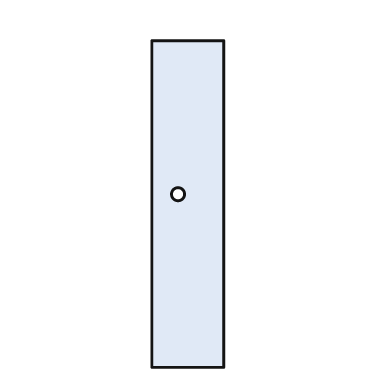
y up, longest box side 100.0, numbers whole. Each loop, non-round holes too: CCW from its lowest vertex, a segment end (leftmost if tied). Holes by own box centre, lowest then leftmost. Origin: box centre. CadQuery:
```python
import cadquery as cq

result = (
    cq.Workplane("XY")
    .moveTo(-11.0, -50.0)
    .lineTo(11.0, -50.0)
    .lineTo(11.0, 50.0)
    .lineTo(-11.0, 50.0)
    .close()
    .moveTo(-3.0, 3.0)
    .circle(2.0)
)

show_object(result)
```